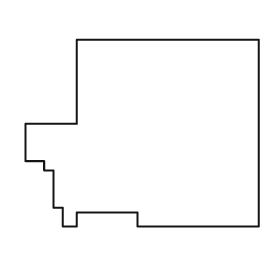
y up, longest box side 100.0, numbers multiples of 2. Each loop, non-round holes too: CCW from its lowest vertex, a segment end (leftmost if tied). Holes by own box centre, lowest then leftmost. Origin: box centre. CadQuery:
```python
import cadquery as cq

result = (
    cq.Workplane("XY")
    .moveTo(-34.0, -40.0)
    .lineTo(-28.0, -40.0)
    .lineTo(-28.0, -34.0)
    .lineTo(-2.0, -34.0)
    .lineTo(-2.0, -40.0)
    .lineTo(50.0, -40.0)
    .lineTo(50.0, 40.0)
    .lineTo(-28.0, 40.0)
    .lineTo(-28.0, 4.0)
    .lineTo(-50.0, 4.0)
    .lineTo(-50.0, -12.0)
    .lineTo(-42.0, -12.0)
    .lineTo(-42.0, -16.0)
    .lineTo(-38.0, -16.0)
    .lineTo(-38.0, -32.0)
    .lineTo(-34.0, -32.0)
    .close()
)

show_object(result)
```